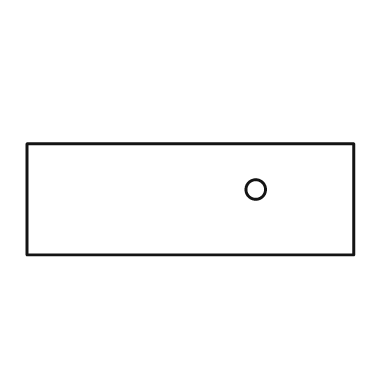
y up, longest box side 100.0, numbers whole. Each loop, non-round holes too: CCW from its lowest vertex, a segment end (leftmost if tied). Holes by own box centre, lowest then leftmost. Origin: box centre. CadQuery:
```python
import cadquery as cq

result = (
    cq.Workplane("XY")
    .moveTo(-50.0, -17.0)
    .lineTo(50.0, -17.0)
    .lineTo(50.0, 17.0)
    .lineTo(-50.0, 17.0)
    .close()
    .moveTo(20.0, 3.0)
    .circle(3.0)
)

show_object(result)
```